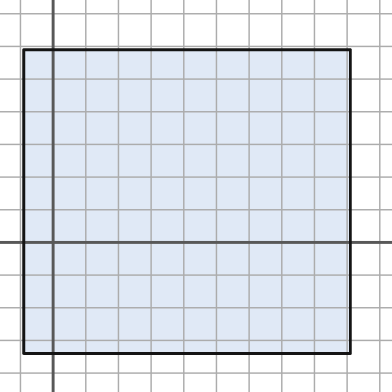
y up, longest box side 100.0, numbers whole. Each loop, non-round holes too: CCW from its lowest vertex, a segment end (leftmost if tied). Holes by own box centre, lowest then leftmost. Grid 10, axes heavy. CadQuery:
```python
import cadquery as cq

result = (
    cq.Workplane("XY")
    .moveTo(-9.0, -34.0)
    .lineTo(91.0, -34.0)
    .lineTo(91.0, 59.0)
    .lineTo(-9.0, 59.0)
    .close()
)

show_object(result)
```